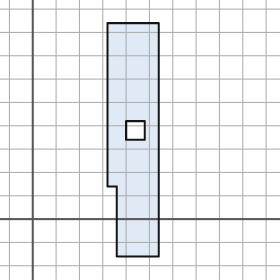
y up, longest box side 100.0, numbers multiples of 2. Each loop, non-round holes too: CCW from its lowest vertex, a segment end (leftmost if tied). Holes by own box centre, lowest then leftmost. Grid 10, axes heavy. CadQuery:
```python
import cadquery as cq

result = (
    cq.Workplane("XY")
    .moveTo(36.0, -16.0)
    .lineTo(54.0, -16.0)
    .lineTo(54.0, 84.0)
    .lineTo(32.0, 84.0)
    .lineTo(32.0, 14.0)
    .lineTo(36.0, 14.0)
    .close()
    .moveTo(40.0, 34.0)
    .lineTo(48.0, 34.0)
    .lineTo(48.0, 42.0)
    .lineTo(40.0, 42.0)
    .close()
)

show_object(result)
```